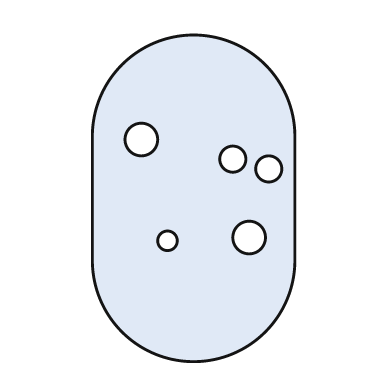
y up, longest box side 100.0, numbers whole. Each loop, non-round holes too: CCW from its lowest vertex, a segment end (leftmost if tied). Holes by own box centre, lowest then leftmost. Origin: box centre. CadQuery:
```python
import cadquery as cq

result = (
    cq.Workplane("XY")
    .moveTo(-31.0, -19.0)
    .threePointArc((0.0, -50.0), (31.0, -19.0))
    .lineTo(31.0, 19.0)
    .threePointArc((0.0, 50.0), (-31.0, 19.0))
    .close()
    .moveTo(-8.0, -13.0)
    .circle(3.0)
    .moveTo(17.0, -12.0)
    .circle(5.0)
    .moveTo(23.0, 9.0)
    .circle(4.0)
    .moveTo(12.0, 12.0)
    .circle(4.0)
    .moveTo(-16.0, 18.0)
    .circle(5.0)
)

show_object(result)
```